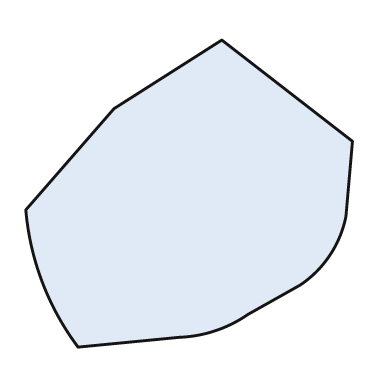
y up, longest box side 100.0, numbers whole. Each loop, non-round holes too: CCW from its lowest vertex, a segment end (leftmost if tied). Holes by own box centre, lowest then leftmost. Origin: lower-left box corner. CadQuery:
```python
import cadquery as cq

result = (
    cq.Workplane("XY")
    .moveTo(16.0, 0.0)
    .lineTo(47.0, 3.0)
    .threePointArc((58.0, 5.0), (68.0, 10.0))
    .lineTo(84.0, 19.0)
    .threePointArc((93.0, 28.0), (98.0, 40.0))
    .lineTo(100.0, 63.0)
    .lineTo(60.0, 94.0)
    .lineTo(27.0, 73.0)
    .lineTo(0.0, 42.0)
    .threePointArc((5.0, 20.0), (16.0, 0.0))
    .close()
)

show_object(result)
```